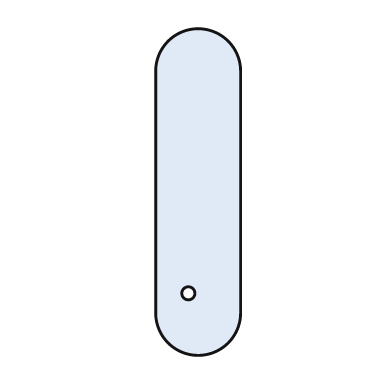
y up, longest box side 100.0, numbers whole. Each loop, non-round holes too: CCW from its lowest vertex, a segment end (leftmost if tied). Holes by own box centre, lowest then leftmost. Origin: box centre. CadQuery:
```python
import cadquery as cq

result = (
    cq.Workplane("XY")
    .moveTo(-13.0, -37.0)
    .threePointArc((0.0, -50.0), (13.0, -37.0))
    .lineTo(13.0, 37.0)
    .threePointArc((0.0, 50.0), (-13.0, 37.0))
    .close()
    .moveTo(-3.0, -31.0)
    .circle(2.0)
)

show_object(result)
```